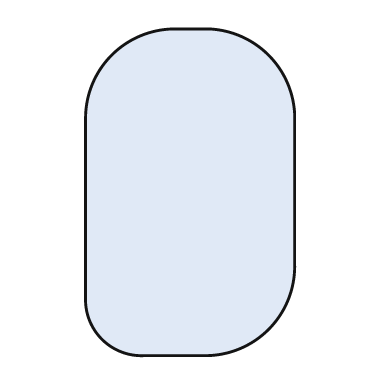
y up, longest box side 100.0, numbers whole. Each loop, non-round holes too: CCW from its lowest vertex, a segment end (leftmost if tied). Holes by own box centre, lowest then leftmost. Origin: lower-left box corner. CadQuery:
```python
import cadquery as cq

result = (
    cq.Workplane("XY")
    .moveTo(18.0, 0.0)
    .lineTo(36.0, 0.0)
    .threePointArc((56.0, 8.0), (64.0, 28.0))
    .lineTo(64.0, 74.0)
    .threePointArc((56.0, 92.0), (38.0, 100.0))
    .lineTo(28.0, 100.0)
    .threePointArc((8.0, 92.0), (0.0, 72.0))
    .lineTo(0.0, 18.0)
    .threePointArc((5.0, 5.0), (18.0, 0.0))
    .close()
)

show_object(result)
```